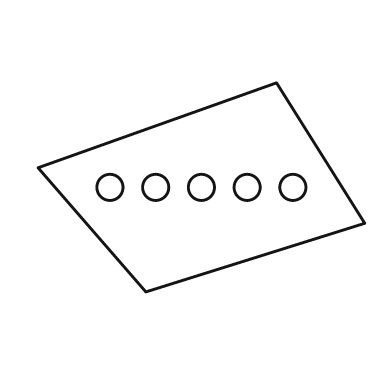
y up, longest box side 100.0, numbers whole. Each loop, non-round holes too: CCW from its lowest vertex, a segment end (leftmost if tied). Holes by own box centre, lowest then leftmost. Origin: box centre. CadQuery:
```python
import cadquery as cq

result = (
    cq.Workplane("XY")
    .moveTo(-17.0, -32.0)
    .lineTo(50.0, -11.0)
    .lineTo(23.0, 32.0)
    .lineTo(-50.0, 6.0)
    .close()
    .moveTo(-28.0, 0.0)
    .circle(4.0)
    .moveTo(-14.0, 0.0)
    .circle(4.0)
    .moveTo(0.0, 0.0)
    .circle(4.0)
    .moveTo(14.0, 0.0)
    .circle(4.0)
    .moveTo(28.0, 0.0)
    .circle(4.0)
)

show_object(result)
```